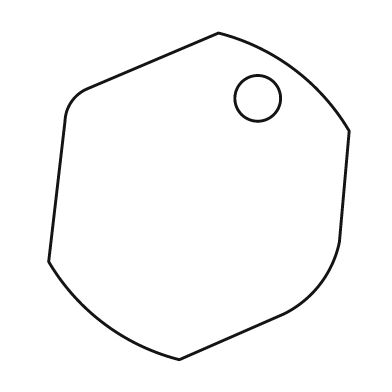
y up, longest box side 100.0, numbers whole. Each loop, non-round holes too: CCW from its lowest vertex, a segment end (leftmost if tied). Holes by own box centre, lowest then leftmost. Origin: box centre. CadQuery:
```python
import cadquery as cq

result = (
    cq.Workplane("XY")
    .moveTo(-6.0, -50.0)
    .lineTo(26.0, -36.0)
    .threePointArc((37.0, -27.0), (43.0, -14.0))
    .lineTo(46.0, 20.0)
    .threePointArc((29.0, 39.0), (6.0, 50.0))
    .lineTo(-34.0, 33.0)
    .threePointArc((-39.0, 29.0), (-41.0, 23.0))
    .lineTo(-46.0, -20.0)
    .threePointArc((-29.0, -39.0), (-6.0, -50.0))
    .close()
    .moveTo(18.0, 30.0)
    .circle(7.0)
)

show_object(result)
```